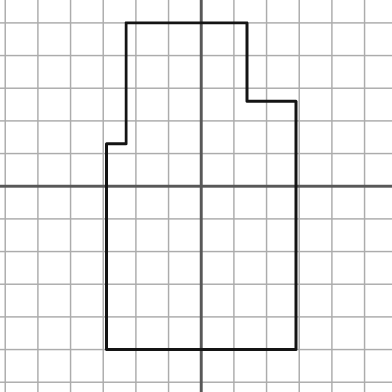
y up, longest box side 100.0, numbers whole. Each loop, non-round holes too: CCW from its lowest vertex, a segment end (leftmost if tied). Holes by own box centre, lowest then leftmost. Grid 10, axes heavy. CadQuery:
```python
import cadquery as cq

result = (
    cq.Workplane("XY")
    .moveTo(-29.0, -50.0)
    .lineTo(29.0, -50.0)
    .lineTo(29.0, 26.0)
    .lineTo(14.0, 26.0)
    .lineTo(14.0, 50.0)
    .lineTo(-23.0, 50.0)
    .lineTo(-23.0, 13.0)
    .lineTo(-29.0, 13.0)
    .close()
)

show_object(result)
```